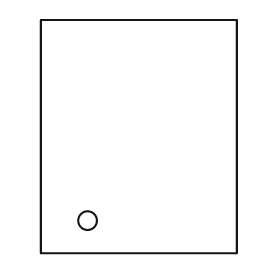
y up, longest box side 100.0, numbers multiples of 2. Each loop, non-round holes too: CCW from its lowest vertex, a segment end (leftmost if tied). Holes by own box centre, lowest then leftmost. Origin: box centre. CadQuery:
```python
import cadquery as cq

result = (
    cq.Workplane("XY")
    .moveTo(-42.0, -50.0)
    .lineTo(42.0, -50.0)
    .lineTo(42.0, 50.0)
    .lineTo(-42.0, 50.0)
    .close()
    .moveTo(-22.0, -36.0)
    .circle(4.0)
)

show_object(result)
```